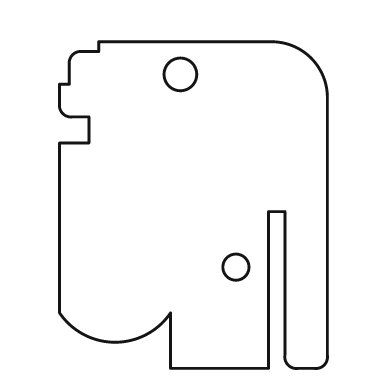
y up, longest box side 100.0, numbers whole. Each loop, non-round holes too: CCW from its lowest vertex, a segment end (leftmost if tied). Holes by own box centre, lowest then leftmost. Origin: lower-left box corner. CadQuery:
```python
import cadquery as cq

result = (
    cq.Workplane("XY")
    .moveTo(34.0, 0.0)
    .lineTo(64.0, 0.0)
    .lineTo(64.0, 48.0)
    .lineTo(69.0, 48.0)
    .lineTo(69.0, 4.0)
    .threePointArc((70.0, 1.0), (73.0, 0.0))
    .lineTo(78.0, 0.0)
    .threePointArc((81.0, 1.0), (82.0, 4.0))
    .lineTo(82.0, 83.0)
    .threePointArc((77.0, 95.0), (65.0, 100.0))
    .lineTo(12.0, 100.0)
    .lineTo(12.0, 97.0)
    .lineTo(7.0, 97.0)
    .threePointArc((4.0, 96.0), (3.0, 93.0))
    .lineTo(3.0, 87.0)
    .lineTo(0.0, 87.0)
    .lineTo(0.0, 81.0)
    .threePointArc((1.0, 78.0), (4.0, 77.0))
    .lineTo(9.0, 77.0)
    .lineTo(9.0, 69.0)
    .lineTo(0.0, 69.0)
    .lineTo(0.0, 17.0)
    .threePointArc((17.0, 8.0), (34.0, 17.0))
    .close()
    .moveTo(54.0, 31.0)
    .circle(4.0)
    .moveTo(37.0, 90.0)
    .circle(5.0)
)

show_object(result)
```